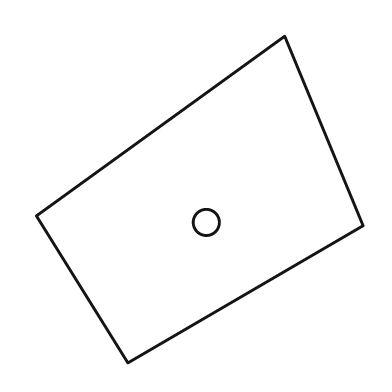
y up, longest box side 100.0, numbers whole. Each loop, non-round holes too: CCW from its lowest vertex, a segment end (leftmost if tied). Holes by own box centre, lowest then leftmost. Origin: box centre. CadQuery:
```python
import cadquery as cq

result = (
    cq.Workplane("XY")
    .moveTo(-22.0, -50.0)
    .lineTo(50.0, -8.0)
    .lineTo(26.0, 50.0)
    .lineTo(-50.0, -5.0)
    .close()
    .moveTo(2.0, -7.0)
    .circle(4.0)
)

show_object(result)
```